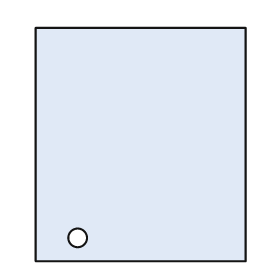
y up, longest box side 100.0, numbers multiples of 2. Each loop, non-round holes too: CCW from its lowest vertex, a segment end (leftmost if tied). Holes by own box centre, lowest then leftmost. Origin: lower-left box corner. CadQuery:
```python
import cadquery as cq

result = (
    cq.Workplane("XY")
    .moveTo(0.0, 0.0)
    .lineTo(90.0, 0.0)
    .lineTo(90.0, 100.0)
    .lineTo(0.0, 100.0)
    .close()
    .moveTo(18.0, 10.0)
    .circle(4.0)
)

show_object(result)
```